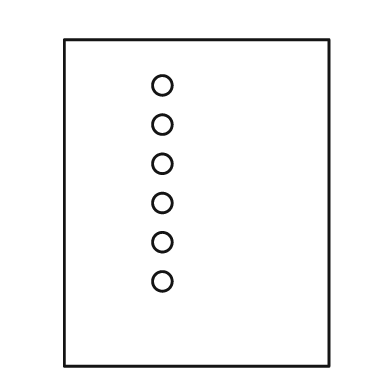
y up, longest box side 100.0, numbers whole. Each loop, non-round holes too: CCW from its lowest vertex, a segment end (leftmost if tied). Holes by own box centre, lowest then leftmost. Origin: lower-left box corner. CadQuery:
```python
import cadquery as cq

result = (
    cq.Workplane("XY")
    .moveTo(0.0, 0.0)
    .lineTo(81.0, 0.0)
    .lineTo(81.0, 100.0)
    .lineTo(0.0, 100.0)
    .close()
    .moveTo(30.0, 26.0)
    .circle(3.0)
    .moveTo(30.0, 38.0)
    .circle(3.0)
    .moveTo(30.0, 50.0)
    .circle(3.0)
    .moveTo(30.0, 62.0)
    .circle(3.0)
    .moveTo(30.0, 74.0)
    .circle(3.0)
    .moveTo(30.0, 86.0)
    .circle(3.0)
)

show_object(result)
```